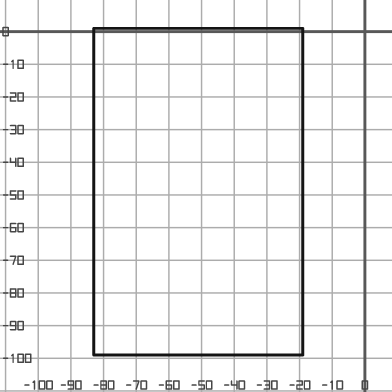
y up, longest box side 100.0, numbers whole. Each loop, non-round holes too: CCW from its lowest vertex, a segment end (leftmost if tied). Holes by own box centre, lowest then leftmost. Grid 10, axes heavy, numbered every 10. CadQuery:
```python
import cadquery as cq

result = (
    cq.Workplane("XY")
    .moveTo(-83.0, -99.0)
    .lineTo(-19.0, -99.0)
    .lineTo(-19.0, 1.0)
    .lineTo(-83.0, 1.0)
    .close()
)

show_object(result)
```